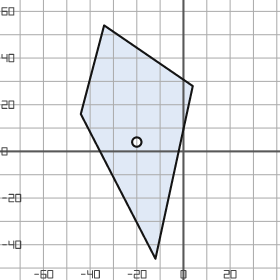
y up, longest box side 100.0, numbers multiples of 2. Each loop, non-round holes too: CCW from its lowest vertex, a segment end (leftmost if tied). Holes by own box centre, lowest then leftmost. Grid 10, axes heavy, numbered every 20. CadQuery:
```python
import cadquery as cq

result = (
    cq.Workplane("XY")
    .moveTo(-12.0, -46.0)
    .lineTo(4.0, 28.0)
    .lineTo(-34.0, 54.0)
    .lineTo(-44.0, 16.0)
    .close()
    .moveTo(-20.0, 4.0)
    .circle(2.0)
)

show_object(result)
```